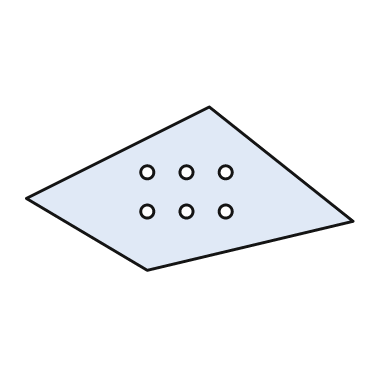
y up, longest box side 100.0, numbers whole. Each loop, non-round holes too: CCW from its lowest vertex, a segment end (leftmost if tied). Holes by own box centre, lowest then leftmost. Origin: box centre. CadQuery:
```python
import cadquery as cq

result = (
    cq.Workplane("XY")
    .moveTo(-13.0, -25.0)
    .lineTo(50.0, -10.0)
    .lineTo(6.0, 25.0)
    .lineTo(-50.0, -3.0)
    .close()
    .moveTo(-13.0, -7.0)
    .circle(2.0)
    .moveTo(-1.0, -7.0)
    .circle(2.0)
    .moveTo(11.0, -7.0)
    .circle(2.0)
    .moveTo(-13.0, 5.0)
    .circle(2.0)
    .moveTo(-1.0, 5.0)
    .circle(2.0)
    .moveTo(11.0, 5.0)
    .circle(2.0)
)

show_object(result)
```